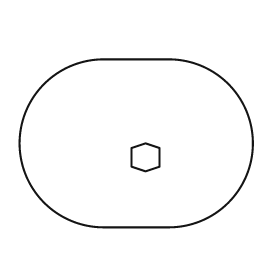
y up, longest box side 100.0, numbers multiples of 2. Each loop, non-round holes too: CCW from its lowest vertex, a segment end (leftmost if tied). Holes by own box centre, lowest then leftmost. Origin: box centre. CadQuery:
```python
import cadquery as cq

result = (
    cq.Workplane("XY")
    .moveTo(-14.0, -36.0)
    .lineTo(14.0, -36.0)
    .threePointArc((50.0, 0.0), (14.0, 36.0))
    .lineTo(-14.0, 36.0)
    .threePointArc((-50.0, 0.0), (-14.0, -36.0))
    .close()
    .moveTo(4.0, -12.0)
    .lineTo(10.0, -10.0)
    .lineTo(10.0, -2.0)
    .lineTo(4.0, 0.0)
    .lineTo(-2.0, -2.0)
    .lineTo(-2.0, -10.0)
    .close()
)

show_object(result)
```